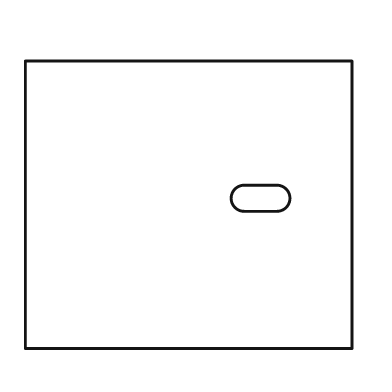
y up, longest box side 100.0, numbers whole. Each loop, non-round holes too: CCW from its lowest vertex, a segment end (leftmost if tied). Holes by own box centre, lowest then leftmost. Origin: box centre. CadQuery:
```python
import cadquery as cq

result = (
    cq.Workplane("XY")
    .moveTo(-50.0, -44.0)
    .lineTo(50.0, -44.0)
    .lineTo(50.0, 44.0)
    .lineTo(-50.0, 44.0)
    .close()
    .moveTo(17.0, -2.0)
    .lineTo(27.0, -2.0)
    .threePointArc((31.0, 2.0), (27.0, 6.0))
    .lineTo(17.0, 6.0)
    .threePointArc((13.0, 2.0), (17.0, -2.0))
    .close()
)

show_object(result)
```